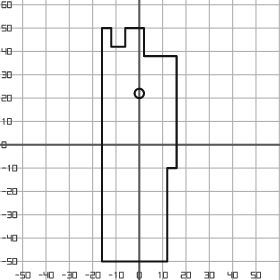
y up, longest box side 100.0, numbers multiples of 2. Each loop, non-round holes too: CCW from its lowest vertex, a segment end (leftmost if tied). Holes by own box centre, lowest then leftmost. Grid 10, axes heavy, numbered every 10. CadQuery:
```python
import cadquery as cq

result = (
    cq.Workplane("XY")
    .moveTo(-16.0, -50.0)
    .lineTo(12.0, -50.0)
    .lineTo(12.0, -10.0)
    .lineTo(16.0, -10.0)
    .lineTo(16.0, 38.0)
    .lineTo(2.0, 38.0)
    .lineTo(2.0, 50.0)
    .lineTo(-6.0, 50.0)
    .lineTo(-6.0, 42.0)
    .lineTo(-12.0, 42.0)
    .lineTo(-12.0, 50.0)
    .lineTo(-16.0, 50.0)
    .close()
    .moveTo(0.0, 22.0)
    .circle(2.0)
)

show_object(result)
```